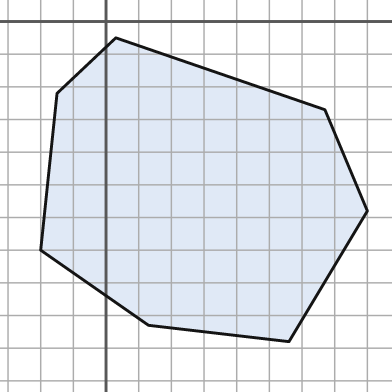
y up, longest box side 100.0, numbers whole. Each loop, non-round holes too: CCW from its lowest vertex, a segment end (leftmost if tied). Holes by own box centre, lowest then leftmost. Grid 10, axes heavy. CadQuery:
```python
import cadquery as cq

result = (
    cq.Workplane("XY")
    .moveTo(56.0, -98.0)
    .lineTo(80.0, -58.0)
    .lineTo(67.0, -27.0)
    .lineTo(3.0, -5.0)
    .lineTo(-15.0, -22.0)
    .lineTo(-20.0, -70.0)
    .lineTo(13.0, -93.0)
    .close()
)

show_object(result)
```